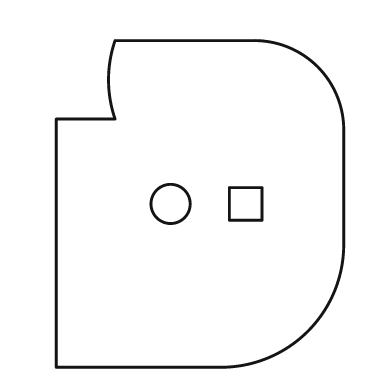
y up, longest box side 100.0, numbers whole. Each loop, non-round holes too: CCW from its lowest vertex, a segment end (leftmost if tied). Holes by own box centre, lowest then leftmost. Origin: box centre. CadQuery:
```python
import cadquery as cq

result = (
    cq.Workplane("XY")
    .moveTo(-44.0, -50.0)
    .lineTo(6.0, -50.0)
    .threePointArc((33.0, -39.0), (44.0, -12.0))
    .lineTo(44.0, 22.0)
    .threePointArc((36.0, 42.0), (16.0, 50.0))
    .lineTo(-26.0, 50.0)
    .threePointArc((-28.0, 38.0), (-26.0, 26.0))
    .lineTo(-44.0, 26.0)
    .close()
    .moveTo(-9.0, 0.0)
    .circle(6.0)
    .moveTo(9.0, -5.0)
    .lineTo(19.0, -5.0)
    .lineTo(19.0, 5.0)
    .lineTo(9.0, 5.0)
    .close()
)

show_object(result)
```